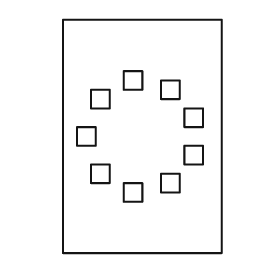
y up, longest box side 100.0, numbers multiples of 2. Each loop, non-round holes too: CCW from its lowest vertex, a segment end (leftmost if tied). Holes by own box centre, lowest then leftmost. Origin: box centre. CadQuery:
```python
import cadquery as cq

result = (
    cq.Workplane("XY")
    .moveTo(-34.0, -50.0)
    .lineTo(34.0, -50.0)
    .lineTo(34.0, 50.0)
    .lineTo(-34.0, 50.0)
    .close()
    .moveTo(-8.0, -28.0)
    .lineTo(0.0, -28.0)
    .lineTo(0.0, -20.0)
    .lineTo(-8.0, -20.0)
    .close()
    .moveTo(8.0, -24.0)
    .lineTo(16.0, -24.0)
    .lineTo(16.0, -16.0)
    .lineTo(8.0, -16.0)
    .close()
    .moveTo(-22.0, -20.0)
    .lineTo(-14.0, -20.0)
    .lineTo(-14.0, -12.0)
    .lineTo(-22.0, -12.0)
    .close()
    .moveTo(18.0, -12.0)
    .lineTo(26.0, -12.0)
    .lineTo(26.0, -4.0)
    .lineTo(18.0, -4.0)
    .close()
    .moveTo(-28.0, -4.0)
    .lineTo(-20.0, -4.0)
    .lineTo(-20.0, 4.0)
    .lineTo(-28.0, 4.0)
    .close()
    .moveTo(18.0, 4.0)
    .lineTo(26.0, 4.0)
    .lineTo(26.0, 12.0)
    .lineTo(18.0, 12.0)
    .close()
    .moveTo(-22.0, 12.0)
    .lineTo(-14.0, 12.0)
    .lineTo(-14.0, 20.0)
    .lineTo(-22.0, 20.0)
    .close()
    .moveTo(8.0, 16.0)
    .lineTo(16.0, 16.0)
    .lineTo(16.0, 24.0)
    .lineTo(8.0, 24.0)
    .close()
    .moveTo(-8.0, 20.0)
    .lineTo(0.0, 20.0)
    .lineTo(0.0, 28.0)
    .lineTo(-8.0, 28.0)
    .close()
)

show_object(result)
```